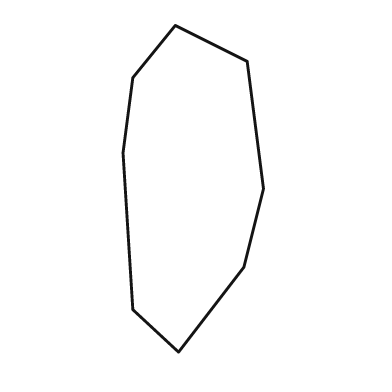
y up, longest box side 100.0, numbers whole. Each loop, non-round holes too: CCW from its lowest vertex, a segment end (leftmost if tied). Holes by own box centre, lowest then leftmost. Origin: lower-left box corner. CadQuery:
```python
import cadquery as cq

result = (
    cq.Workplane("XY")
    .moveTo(17.0, 0.0)
    .lineTo(37.0, 26.0)
    .lineTo(43.0, 50.0)
    .lineTo(38.0, 89.0)
    .lineTo(16.0, 100.0)
    .lineTo(3.0, 84.0)
    .lineTo(0.0, 61.0)
    .lineTo(3.0, 13.0)
    .close()
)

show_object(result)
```